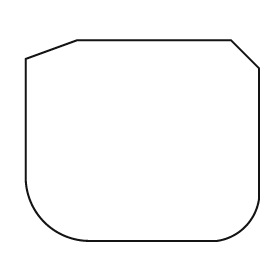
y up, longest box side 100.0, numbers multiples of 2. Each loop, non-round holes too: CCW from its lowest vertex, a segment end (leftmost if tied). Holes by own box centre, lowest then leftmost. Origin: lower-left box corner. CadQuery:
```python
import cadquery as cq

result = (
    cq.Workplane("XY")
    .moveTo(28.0, 0.0)
    .lineTo(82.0, 0.0)
    .threePointArc((94.0, 6.0), (100.0, 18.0))
    .lineTo(100.0, 74.0)
    .lineTo(88.0, 86.0)
    .lineTo(22.0, 86.0)
    .lineTo(0.0, 78.0)
    .lineTo(0.0, 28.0)
    .threePointArc((8.0, 8.0), (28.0, 0.0))
    .close()
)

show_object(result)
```